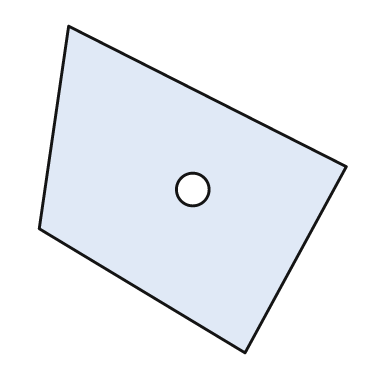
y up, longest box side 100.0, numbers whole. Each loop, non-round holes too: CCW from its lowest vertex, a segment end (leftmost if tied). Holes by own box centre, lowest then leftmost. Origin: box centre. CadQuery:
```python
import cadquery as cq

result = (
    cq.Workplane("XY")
    .moveTo(16.0, -50.0)
    .lineTo(47.0, 7.0)
    .lineTo(-38.0, 50.0)
    .lineTo(-47.0, -12.0)
    .close()
    .moveTo(0.0, 0.0)
    .circle(5.0)
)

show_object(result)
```